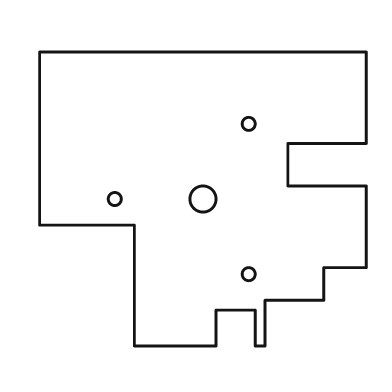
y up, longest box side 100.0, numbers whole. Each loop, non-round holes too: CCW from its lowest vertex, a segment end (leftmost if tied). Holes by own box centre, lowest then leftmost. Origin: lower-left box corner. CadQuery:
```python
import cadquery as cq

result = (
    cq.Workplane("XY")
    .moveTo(29.0, 0.0)
    .lineTo(54.0, 0.0)
    .lineTo(54.0, 11.0)
    .lineTo(66.0, 11.0)
    .lineTo(66.0, 0.0)
    .lineTo(69.0, 0.0)
    .lineTo(69.0, 14.0)
    .lineTo(87.0, 14.0)
    .lineTo(87.0, 24.0)
    .lineTo(100.0, 24.0)
    .lineTo(100.0, 49.0)
    .lineTo(76.0, 49.0)
    .lineTo(76.0, 62.0)
    .lineTo(100.0, 62.0)
    .lineTo(100.0, 90.0)
    .lineTo(0.0, 90.0)
    .lineTo(0.0, 37.0)
    .lineTo(29.0, 37.0)
    .close()
    .moveTo(64.0, 22.0)
    .circle(2.0)
    .moveTo(23.0, 45.0)
    .circle(2.0)
    .moveTo(50.0, 45.0)
    .circle(4.0)
    .moveTo(64.0, 68.0)
    .circle(2.0)
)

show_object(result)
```